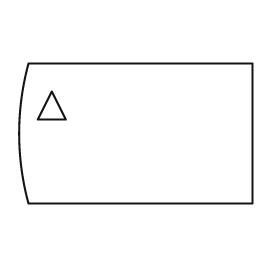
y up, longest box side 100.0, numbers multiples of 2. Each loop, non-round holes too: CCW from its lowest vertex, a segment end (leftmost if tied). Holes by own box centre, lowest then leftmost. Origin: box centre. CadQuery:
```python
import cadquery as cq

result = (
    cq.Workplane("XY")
    .moveTo(-46.0, -30.0)
    .lineTo(50.0, -30.0)
    .lineTo(50.0, 30.0)
    .lineTo(-46.0, 30.0)
    .threePointArc((-50.0, 0.0), (-46.0, -30.0))
    .close()
    .moveTo(-42.0, 6.0)
    .lineTo(-30.0, 6.0)
    .lineTo(-36.0, 18.0)
    .close()
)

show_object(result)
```